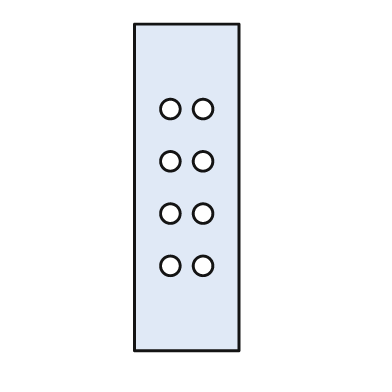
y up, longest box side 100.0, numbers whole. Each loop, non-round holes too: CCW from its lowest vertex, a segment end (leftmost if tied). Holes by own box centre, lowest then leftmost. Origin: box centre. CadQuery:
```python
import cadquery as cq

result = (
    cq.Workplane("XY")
    .moveTo(-16.0, -50.0)
    .lineTo(16.0, -50.0)
    .lineTo(16.0, 50.0)
    .lineTo(-16.0, 50.0)
    .close()
    .moveTo(-5.0, -24.0)
    .circle(3.0)
    .moveTo(5.0, -24.0)
    .circle(3.0)
    .moveTo(-5.0, -8.0)
    .circle(3.0)
    .moveTo(5.0, -8.0)
    .circle(3.0)
    .moveTo(-5.0, 8.0)
    .circle(3.0)
    .moveTo(5.0, 8.0)
    .circle(3.0)
    .moveTo(-5.0, 24.0)
    .circle(3.0)
    .moveTo(5.0, 24.0)
    .circle(3.0)
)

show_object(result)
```